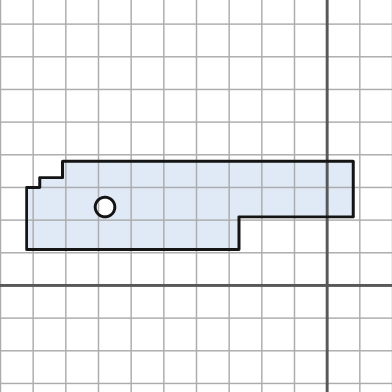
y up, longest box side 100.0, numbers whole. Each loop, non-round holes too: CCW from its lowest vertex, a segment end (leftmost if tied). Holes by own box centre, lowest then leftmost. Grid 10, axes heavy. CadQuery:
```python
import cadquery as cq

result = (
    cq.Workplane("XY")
    .moveTo(-92.0, 11.0)
    .lineTo(-27.0, 11.0)
    .lineTo(-27.0, 21.0)
    .lineTo(8.0, 21.0)
    .lineTo(8.0, 38.0)
    .lineTo(-81.0, 38.0)
    .lineTo(-81.0, 33.0)
    .lineTo(-88.0, 33.0)
    .lineTo(-88.0, 30.0)
    .lineTo(-92.0, 30.0)
    .close()
    .moveTo(-68.0, 24.0)
    .circle(3.0)
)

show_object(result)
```